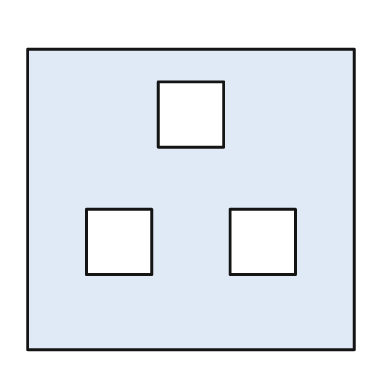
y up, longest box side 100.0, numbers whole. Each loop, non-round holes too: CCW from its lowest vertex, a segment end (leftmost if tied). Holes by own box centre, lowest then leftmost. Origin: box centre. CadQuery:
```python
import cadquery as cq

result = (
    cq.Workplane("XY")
    .moveTo(-50.0, -46.0)
    .lineTo(50.0, -46.0)
    .lineTo(50.0, 46.0)
    .lineTo(-50.0, 46.0)
    .close()
    .moveTo(-32.0, -23.0)
    .lineTo(-12.0, -23.0)
    .lineTo(-12.0, -3.0)
    .lineTo(-32.0, -3.0)
    .close()
    .moveTo(12.0, -23.0)
    .lineTo(32.0, -23.0)
    .lineTo(32.0, -3.0)
    .lineTo(12.0, -3.0)
    .close()
    .moveTo(-10.0, 16.0)
    .lineTo(10.0, 16.0)
    .lineTo(10.0, 36.0)
    .lineTo(-10.0, 36.0)
    .close()
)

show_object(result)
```